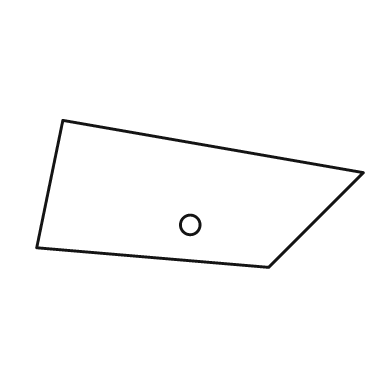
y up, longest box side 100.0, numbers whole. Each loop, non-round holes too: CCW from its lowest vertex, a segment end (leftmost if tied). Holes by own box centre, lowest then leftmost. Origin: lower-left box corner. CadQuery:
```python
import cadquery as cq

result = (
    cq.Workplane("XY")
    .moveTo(71.0, 0.0)
    .lineTo(100.0, 29.0)
    .lineTo(8.0, 45.0)
    .lineTo(0.0, 6.0)
    .close()
    .moveTo(47.0, 13.0)
    .circle(3.0)
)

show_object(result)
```